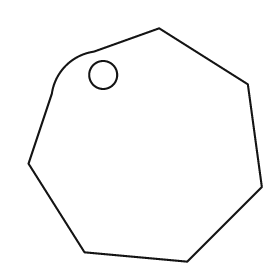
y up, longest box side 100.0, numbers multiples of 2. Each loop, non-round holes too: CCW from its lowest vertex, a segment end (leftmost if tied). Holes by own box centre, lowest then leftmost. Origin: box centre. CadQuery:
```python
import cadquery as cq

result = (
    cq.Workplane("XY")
    .moveTo(18.0, -50.0)
    .lineTo(50.0, -18.0)
    .lineTo(44.0, 26.0)
    .lineTo(6.0, 50.0)
    .lineTo(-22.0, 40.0)
    .threePointArc((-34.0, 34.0), (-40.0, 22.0))
    .lineTo(-50.0, -8.0)
    .lineTo(-26.0, -46.0)
    .close()
    .moveTo(-18.0, 30.0)
    .circle(6.0)
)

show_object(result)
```